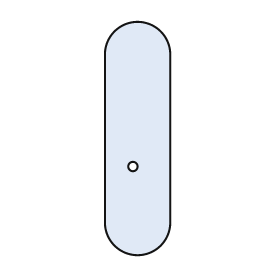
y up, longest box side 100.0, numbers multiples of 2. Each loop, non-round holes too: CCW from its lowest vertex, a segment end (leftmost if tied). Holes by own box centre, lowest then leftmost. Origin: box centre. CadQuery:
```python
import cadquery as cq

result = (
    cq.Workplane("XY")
    .moveTo(-14.0, -36.0)
    .threePointArc((0.0, -50.0), (14.0, -36.0))
    .lineTo(14.0, 36.0)
    .threePointArc((0.0, 50.0), (-14.0, 36.0))
    .close()
    .moveTo(-2.0, -12.0)
    .circle(2.0)
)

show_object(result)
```